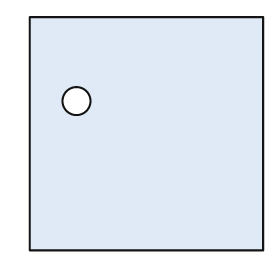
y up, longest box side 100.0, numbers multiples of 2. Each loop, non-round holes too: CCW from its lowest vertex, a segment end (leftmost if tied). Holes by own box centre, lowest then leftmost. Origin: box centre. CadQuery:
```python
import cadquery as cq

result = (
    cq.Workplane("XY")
    .moveTo(-50.0, -50.0)
    .lineTo(50.0, -50.0)
    .lineTo(50.0, 50.0)
    .lineTo(-50.0, 50.0)
    .close()
    .moveTo(-30.0, 14.0)
    .circle(6.0)
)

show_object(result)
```